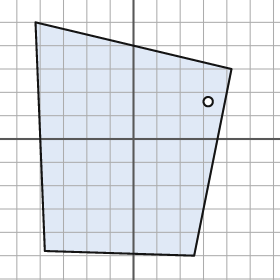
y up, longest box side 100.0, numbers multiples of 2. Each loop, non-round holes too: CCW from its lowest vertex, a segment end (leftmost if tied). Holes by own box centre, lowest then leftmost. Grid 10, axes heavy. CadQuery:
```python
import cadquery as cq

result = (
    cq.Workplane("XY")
    .moveTo(26.0, -50.0)
    .lineTo(42.0, 30.0)
    .lineTo(-42.0, 50.0)
    .lineTo(-38.0, -48.0)
    .close()
    .moveTo(32.0, 16.0)
    .circle(2.0)
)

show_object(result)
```